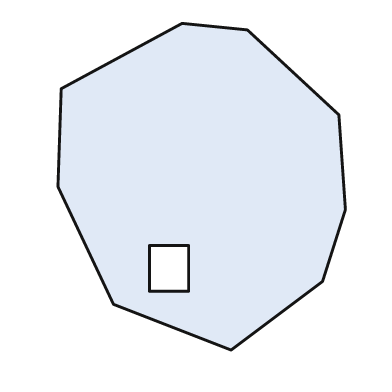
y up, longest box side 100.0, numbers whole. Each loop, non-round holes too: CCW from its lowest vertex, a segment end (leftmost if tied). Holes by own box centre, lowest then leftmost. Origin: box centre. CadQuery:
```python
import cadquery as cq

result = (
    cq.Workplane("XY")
    .moveTo(9.0, -50.0)
    .lineTo(37.0, -29.0)
    .lineTo(44.0, -7.0)
    .lineTo(42.0, 22.0)
    .lineTo(14.0, 48.0)
    .lineTo(-6.0, 50.0)
    .lineTo(-43.0, 30.0)
    .lineTo(-44.0, 0.0)
    .lineTo(-27.0, -36.0)
    .close()
    .moveTo(-16.0, -32.0)
    .lineTo(-4.0, -32.0)
    .lineTo(-4.0, -18.0)
    .lineTo(-16.0, -18.0)
    .close()
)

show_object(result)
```